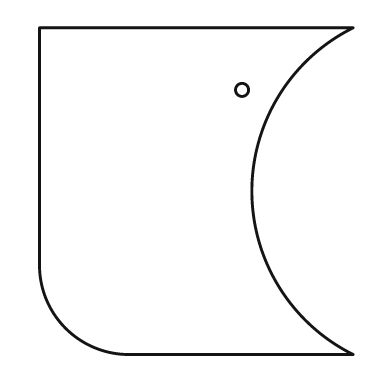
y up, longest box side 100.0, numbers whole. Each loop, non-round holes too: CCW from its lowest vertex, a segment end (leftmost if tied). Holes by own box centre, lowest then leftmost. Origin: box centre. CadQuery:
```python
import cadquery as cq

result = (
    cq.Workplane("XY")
    .moveTo(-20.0, -50.0)
    .lineTo(48.0, -50.0)
    .threePointArc((17.0, 0.0), (48.0, 50.0))
    .lineTo(-48.0, 50.0)
    .lineTo(-48.0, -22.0)
    .threePointArc((-40.0, -42.0), (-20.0, -50.0))
    .close()
    .moveTo(14.0, 31.0)
    .circle(2.0)
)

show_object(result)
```